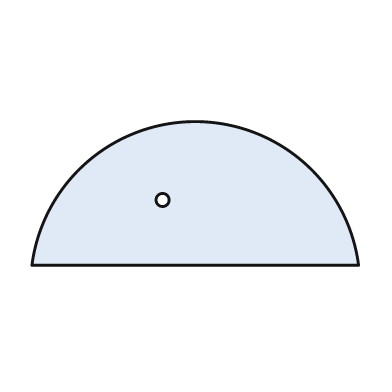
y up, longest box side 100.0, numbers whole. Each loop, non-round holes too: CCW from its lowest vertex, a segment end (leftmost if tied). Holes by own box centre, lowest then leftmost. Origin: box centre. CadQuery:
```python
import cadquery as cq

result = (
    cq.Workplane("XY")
    .moveTo(-50.0, -22.0)
    .lineTo(50.0, -22.0)
    .threePointArc((0.0, 22.0), (-50.0, -22.0))
    .close()
    .moveTo(-10.0, -2.0)
    .circle(2.0)
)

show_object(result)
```